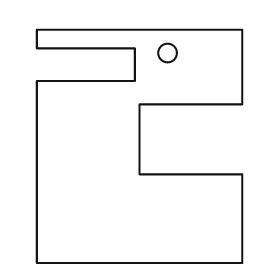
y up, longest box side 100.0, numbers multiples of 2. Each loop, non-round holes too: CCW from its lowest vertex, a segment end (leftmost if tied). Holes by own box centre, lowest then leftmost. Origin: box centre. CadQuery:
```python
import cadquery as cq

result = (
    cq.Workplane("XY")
    .moveTo(-44.0, -50.0)
    .lineTo(44.0, -50.0)
    .lineTo(44.0, -12.0)
    .lineTo(0.0, -12.0)
    .lineTo(0.0, 18.0)
    .lineTo(44.0, 18.0)
    .lineTo(44.0, 50.0)
    .lineTo(-44.0, 50.0)
    .lineTo(-44.0, 42.0)
    .lineTo(-2.0, 42.0)
    .lineTo(-2.0, 28.0)
    .lineTo(-44.0, 28.0)
    .close()
    .moveTo(12.0, 40.0)
    .circle(4.0)
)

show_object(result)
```